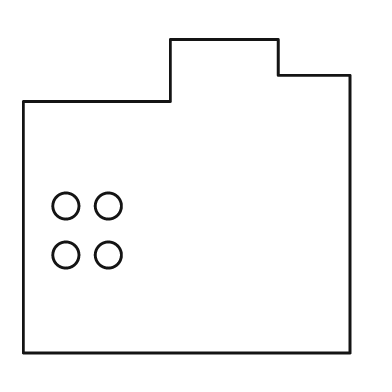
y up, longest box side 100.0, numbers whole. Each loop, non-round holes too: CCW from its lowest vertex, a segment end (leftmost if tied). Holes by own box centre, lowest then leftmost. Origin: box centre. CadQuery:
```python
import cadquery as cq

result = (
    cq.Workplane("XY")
    .moveTo(-50.0, -48.0)
    .lineTo(50.0, -48.0)
    .lineTo(50.0, 37.0)
    .lineTo(28.0, 37.0)
    .lineTo(28.0, 48.0)
    .lineTo(-5.0, 48.0)
    .lineTo(-5.0, 29.0)
    .lineTo(-50.0, 29.0)
    .close()
    .moveTo(-37.0, -18.0)
    .circle(4.0)
    .moveTo(-24.0, -18.0)
    .circle(4.0)
    .moveTo(-37.0, -3.0)
    .circle(4.0)
    .moveTo(-24.0, -3.0)
    .circle(4.0)
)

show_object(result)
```